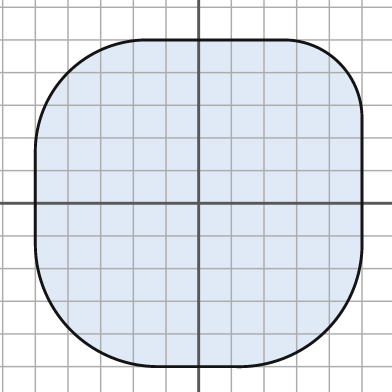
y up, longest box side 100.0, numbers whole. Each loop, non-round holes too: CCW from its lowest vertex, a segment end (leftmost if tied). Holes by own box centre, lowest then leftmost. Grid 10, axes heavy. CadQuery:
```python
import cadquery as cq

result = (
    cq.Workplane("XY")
    .moveTo(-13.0, -50.0)
    .lineTo(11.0, -50.0)
    .threePointArc((39.0, -39.0), (50.0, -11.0))
    .lineTo(50.0, 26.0)
    .threePointArc((43.0, 43.0), (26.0, 50.0))
    .lineTo(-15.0, 50.0)
    .threePointArc((-40.0, 40.0), (-50.0, 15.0))
    .lineTo(-50.0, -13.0)
    .threePointArc((-39.0, -39.0), (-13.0, -50.0))
    .close()
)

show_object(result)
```